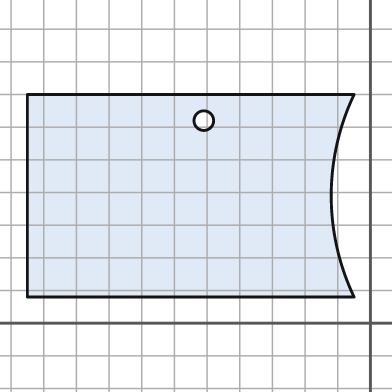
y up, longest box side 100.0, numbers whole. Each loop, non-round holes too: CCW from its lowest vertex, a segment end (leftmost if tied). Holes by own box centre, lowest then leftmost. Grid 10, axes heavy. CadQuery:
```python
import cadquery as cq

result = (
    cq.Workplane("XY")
    .moveTo(-105.0, 8.0)
    .lineTo(-5.0, 8.0)
    .threePointArc((-12.0, 39.0), (-5.0, 70.0))
    .lineTo(-105.0, 70.0)
    .close()
    .moveTo(-51.0, 62.0)
    .circle(3.0)
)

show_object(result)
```